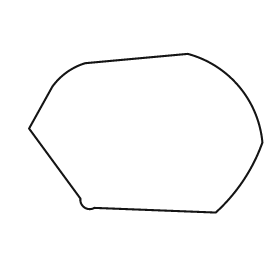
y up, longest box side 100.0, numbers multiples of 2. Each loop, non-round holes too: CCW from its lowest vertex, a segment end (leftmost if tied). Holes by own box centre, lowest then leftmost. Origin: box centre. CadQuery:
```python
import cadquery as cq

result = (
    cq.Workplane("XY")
    .moveTo(30.0, -34.0)
    .threePointArc((42.0, -20.0), (50.0, -4.0))
    .threePointArc((40.0, 20.0), (18.0, 34.0))
    .lineTo(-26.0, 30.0)
    .threePointArc((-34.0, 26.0), (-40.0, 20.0))
    .lineTo(-50.0, 2.0)
    .lineTo(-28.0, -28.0)
    .threePointArc((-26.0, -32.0), (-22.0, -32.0))
    .close()
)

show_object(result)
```